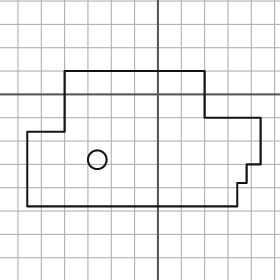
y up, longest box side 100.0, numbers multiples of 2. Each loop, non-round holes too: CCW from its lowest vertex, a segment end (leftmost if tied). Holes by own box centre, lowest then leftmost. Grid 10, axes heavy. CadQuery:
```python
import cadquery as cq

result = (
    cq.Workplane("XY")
    .moveTo(-56.0, -48.0)
    .lineTo(34.0, -48.0)
    .lineTo(34.0, -38.0)
    .lineTo(38.0, -38.0)
    .lineTo(38.0, -30.0)
    .lineTo(44.0, -30.0)
    .lineTo(44.0, -10.0)
    .lineTo(20.0, -10.0)
    .lineTo(20.0, 10.0)
    .lineTo(-40.0, 10.0)
    .lineTo(-40.0, -16.0)
    .lineTo(-56.0, -16.0)
    .close()
    .moveTo(-26.0, -28.0)
    .circle(4.0)
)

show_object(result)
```